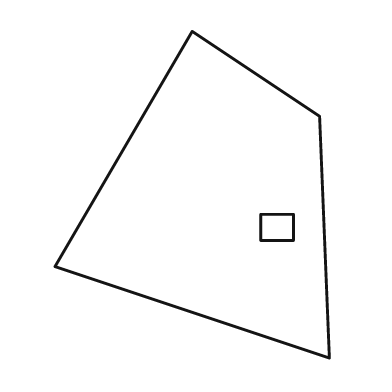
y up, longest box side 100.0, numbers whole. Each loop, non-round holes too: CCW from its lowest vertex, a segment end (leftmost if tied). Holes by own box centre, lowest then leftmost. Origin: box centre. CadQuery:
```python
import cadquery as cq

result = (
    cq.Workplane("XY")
    .moveTo(42.0, -50.0)
    .lineTo(39.0, 24.0)
    .lineTo(0.0, 50.0)
    .lineTo(-42.0, -22.0)
    .close()
    .moveTo(21.0, -14.0)
    .lineTo(31.0, -14.0)
    .lineTo(31.0, -6.0)
    .lineTo(21.0, -6.0)
    .close()
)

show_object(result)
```